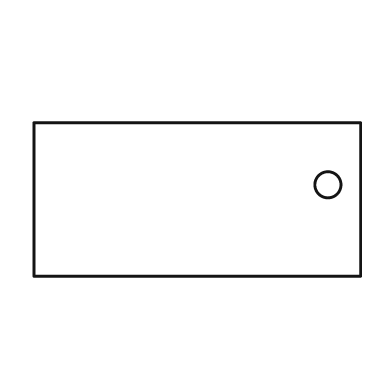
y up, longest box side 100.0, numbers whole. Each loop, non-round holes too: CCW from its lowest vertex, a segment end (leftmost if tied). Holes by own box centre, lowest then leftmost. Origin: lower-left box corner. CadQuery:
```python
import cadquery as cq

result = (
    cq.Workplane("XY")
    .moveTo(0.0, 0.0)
    .lineTo(100.0, 0.0)
    .lineTo(100.0, 47.0)
    .lineTo(0.0, 47.0)
    .close()
    .moveTo(90.0, 28.0)
    .circle(4.0)
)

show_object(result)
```